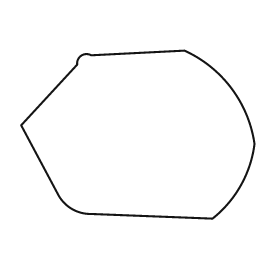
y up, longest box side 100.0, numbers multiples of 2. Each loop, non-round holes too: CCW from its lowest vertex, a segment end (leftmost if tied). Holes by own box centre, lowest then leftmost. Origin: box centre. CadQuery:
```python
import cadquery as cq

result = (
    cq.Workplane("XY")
    .moveTo(32.0, -36.0)
    .threePointArc((44.0, -22.0), (50.0, -4.0))
    .threePointArc((40.0, 20.0), (20.0, 36.0))
    .lineTo(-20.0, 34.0)
    .threePointArc((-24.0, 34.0), (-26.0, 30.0))
    .lineTo(-50.0, 4.0)
    .lineTo(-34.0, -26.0)
    .threePointArc((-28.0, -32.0), (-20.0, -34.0))
    .close()
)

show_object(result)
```